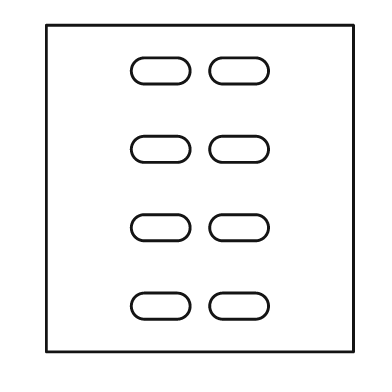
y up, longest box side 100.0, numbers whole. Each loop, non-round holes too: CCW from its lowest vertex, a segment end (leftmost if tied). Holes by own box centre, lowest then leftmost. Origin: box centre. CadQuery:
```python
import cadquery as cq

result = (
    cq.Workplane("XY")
    .moveTo(-47.0, -50.0)
    .lineTo(47.0, -50.0)
    .lineTo(47.0, 50.0)
    .lineTo(-47.0, 50.0)
    .close()
    .moveTo(-17.0, -40.0)
    .lineTo(-7.0, -40.0)
    .threePointArc((-3.0, -36.0), (-7.0, -32.0))
    .lineTo(-17.0, -32.0)
    .threePointArc((-21.0, -36.0), (-17.0, -40.0))
    .close()
    .moveTo(7.0, -40.0)
    .lineTo(17.0, -40.0)
    .threePointArc((21.0, -36.0), (17.0, -32.0))
    .lineTo(7.0, -32.0)
    .threePointArc((3.0, -36.0), (7.0, -40.0))
    .close()
    .moveTo(-17.0, -16.0)
    .lineTo(-7.0, -16.0)
    .threePointArc((-3.0, -12.0), (-7.0, -8.0))
    .lineTo(-17.0, -8.0)
    .threePointArc((-21.0, -12.0), (-17.0, -16.0))
    .close()
    .moveTo(7.0, -16.0)
    .lineTo(17.0, -16.0)
    .threePointArc((21.0, -12.0), (17.0, -8.0))
    .lineTo(7.0, -8.0)
    .threePointArc((3.0, -12.0), (7.0, -16.0))
    .close()
    .moveTo(-17.0, 8.0)
    .lineTo(-7.0, 8.0)
    .threePointArc((-3.0, 12.0), (-7.0, 16.0))
    .lineTo(-17.0, 16.0)
    .threePointArc((-21.0, 12.0), (-17.0, 8.0))
    .close()
    .moveTo(7.0, 8.0)
    .lineTo(17.0, 8.0)
    .threePointArc((21.0, 12.0), (17.0, 16.0))
    .lineTo(7.0, 16.0)
    .threePointArc((3.0, 12.0), (7.0, 8.0))
    .close()
    .moveTo(-17.0, 32.0)
    .lineTo(-7.0, 32.0)
    .threePointArc((-3.0, 36.0), (-7.0, 40.0))
    .lineTo(-17.0, 40.0)
    .threePointArc((-21.0, 36.0), (-17.0, 32.0))
    .close()
    .moveTo(7.0, 32.0)
    .lineTo(17.0, 32.0)
    .threePointArc((21.0, 36.0), (17.0, 40.0))
    .lineTo(7.0, 40.0)
    .threePointArc((3.0, 36.0), (7.0, 32.0))
    .close()
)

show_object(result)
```